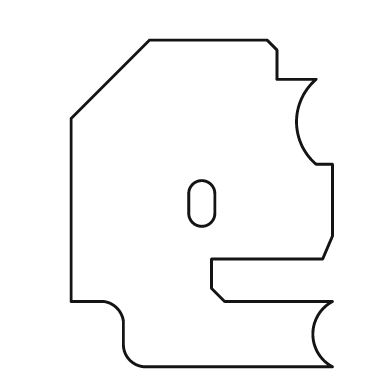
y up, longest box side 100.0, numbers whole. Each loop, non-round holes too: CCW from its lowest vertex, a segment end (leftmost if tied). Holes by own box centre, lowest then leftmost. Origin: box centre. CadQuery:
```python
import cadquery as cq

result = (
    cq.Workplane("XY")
    .moveTo(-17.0, -50.0)
    .lineTo(40.0, -50.0)
    .threePointArc((34.0, -40.0), (40.0, -30.0))
    .lineTo(7.0, -30.0)
    .lineTo(3.0, -26.0)
    .lineTo(3.0, -17.0)
    .lineTo(37.0, -17.0)
    .lineTo(40.0, -10.0)
    .lineTo(40.0, 12.0)
    .lineTo(35.0, 12.0)
    .threePointArc((29.0, 25.0), (35.0, 38.0))
    .lineTo(23.0, 38.0)
    .lineTo(23.0, 47.0)
    .lineTo(20.0, 50.0)
    .lineTo(-16.0, 50.0)
    .lineTo(-40.0, 26.0)
    .lineTo(-40.0, -30.0)
    .lineTo(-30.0, -30.0)
    .threePointArc((-26.0, -32.0), (-24.0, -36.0))
    .lineTo(-24.0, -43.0)
    .threePointArc((-22.0, -48.0), (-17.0, -50.0))
    .close()
    .moveTo(-4.0, -3.0)
    .threePointArc((0.0, -7.0), (4.0, -3.0))
    .lineTo(4.0, 3.0)
    .threePointArc((0.0, 7.0), (-4.0, 3.0))
    .close()
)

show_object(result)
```